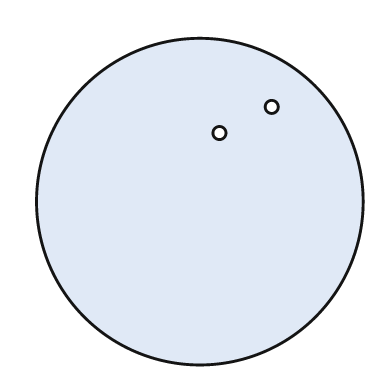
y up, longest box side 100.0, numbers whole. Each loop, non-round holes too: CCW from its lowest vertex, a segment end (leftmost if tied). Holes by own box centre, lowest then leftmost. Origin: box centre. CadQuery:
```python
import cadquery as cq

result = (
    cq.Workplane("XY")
    .moveTo(0.0, 0.0)
    .circle(50.0)
    .moveTo(6.0, 21.0)
    .circle(2.0)
    .moveTo(22.0, 29.0)
    .circle(2.0)
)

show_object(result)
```